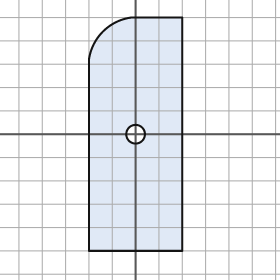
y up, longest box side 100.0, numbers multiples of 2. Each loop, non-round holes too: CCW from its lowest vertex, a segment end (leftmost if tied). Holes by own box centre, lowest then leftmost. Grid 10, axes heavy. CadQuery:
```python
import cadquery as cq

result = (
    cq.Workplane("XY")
    .moveTo(-20.0, -50.0)
    .lineTo(20.0, -50.0)
    .lineTo(20.0, 50.0)
    .lineTo(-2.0, 50.0)
    .threePointArc((-14.0, 44.0), (-20.0, 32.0))
    .close()
    .moveTo(0.0, 0.0)
    .circle(4.0)
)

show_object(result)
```